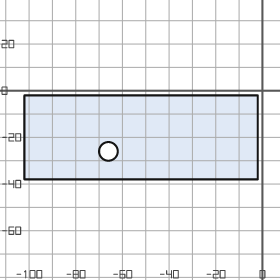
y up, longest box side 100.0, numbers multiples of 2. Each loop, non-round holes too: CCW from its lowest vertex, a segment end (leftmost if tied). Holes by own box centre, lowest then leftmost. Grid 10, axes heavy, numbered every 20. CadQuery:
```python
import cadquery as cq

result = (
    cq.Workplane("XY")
    .moveTo(-102.0, -38.0)
    .lineTo(-2.0, -38.0)
    .lineTo(-2.0, -2.0)
    .lineTo(-102.0, -2.0)
    .close()
    .moveTo(-66.0, -26.0)
    .circle(4.0)
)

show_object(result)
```